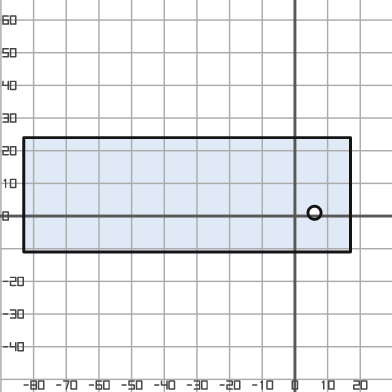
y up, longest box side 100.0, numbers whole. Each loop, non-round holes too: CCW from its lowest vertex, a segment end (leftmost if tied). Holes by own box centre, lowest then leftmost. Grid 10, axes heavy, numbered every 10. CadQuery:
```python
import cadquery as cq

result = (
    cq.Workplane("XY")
    .moveTo(-83.0, -11.0)
    .lineTo(17.0, -11.0)
    .lineTo(17.0, 24.0)
    .lineTo(-83.0, 24.0)
    .close()
    .moveTo(6.0, 1.0)
    .circle(2.0)
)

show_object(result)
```